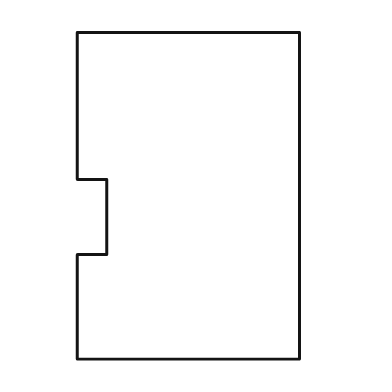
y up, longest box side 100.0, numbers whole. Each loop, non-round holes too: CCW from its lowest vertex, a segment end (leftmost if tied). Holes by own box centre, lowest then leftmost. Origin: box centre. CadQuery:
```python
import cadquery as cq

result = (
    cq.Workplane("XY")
    .moveTo(-34.0, -50.0)
    .lineTo(34.0, -50.0)
    .lineTo(34.0, 50.0)
    .lineTo(-34.0, 50.0)
    .lineTo(-34.0, 5.0)
    .lineTo(-25.0, 5.0)
    .lineTo(-25.0, -18.0)
    .lineTo(-34.0, -18.0)
    .close()
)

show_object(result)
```